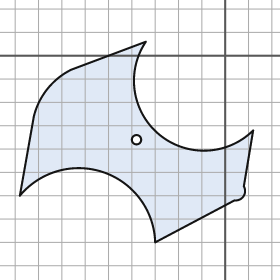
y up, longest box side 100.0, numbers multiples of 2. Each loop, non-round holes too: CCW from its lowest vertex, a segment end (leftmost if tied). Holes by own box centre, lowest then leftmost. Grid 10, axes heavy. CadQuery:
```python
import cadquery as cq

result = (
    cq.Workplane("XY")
    .moveTo(-30.0, -80.0)
    .lineTo(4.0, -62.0)
    .threePointArc((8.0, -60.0), (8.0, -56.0))
    .lineTo(12.0, -32.0)
    .threePointArc((-28.0, -34.0), (-34.0, 6.0))
    .lineTo(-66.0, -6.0)
    .threePointArc((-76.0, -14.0), (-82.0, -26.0))
    .lineTo(-88.0, -60.0)
    .threePointArc((-52.0, -50.0), (-30.0, -80.0))
    .close()
    .moveTo(-38.0, -36.0)
    .circle(2.0)
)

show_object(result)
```